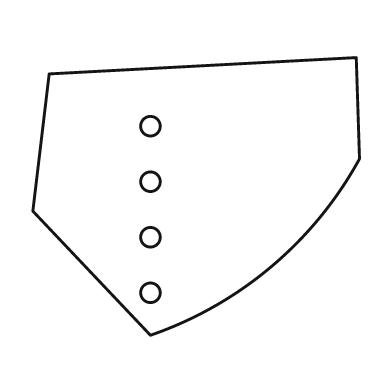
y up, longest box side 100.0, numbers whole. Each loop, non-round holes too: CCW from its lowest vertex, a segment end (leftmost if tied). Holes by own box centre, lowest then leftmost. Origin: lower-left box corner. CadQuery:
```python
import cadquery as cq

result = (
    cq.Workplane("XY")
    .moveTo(36.0, 0.0)
    .threePointArc((73.0, 21.0), (100.0, 54.0))
    .lineTo(99.0, 85.0)
    .lineTo(5.0, 80.0)
    .lineTo(0.0, 38.0)
    .close()
    .moveTo(36.0, 13.0)
    .circle(3.0)
    .moveTo(36.0, 30.0)
    .circle(3.0)
    .moveTo(36.0, 47.0)
    .circle(3.0)
    .moveTo(36.0, 64.0)
    .circle(3.0)
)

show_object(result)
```